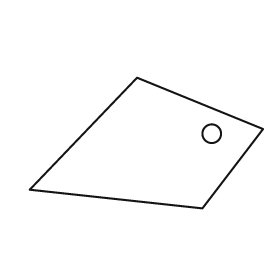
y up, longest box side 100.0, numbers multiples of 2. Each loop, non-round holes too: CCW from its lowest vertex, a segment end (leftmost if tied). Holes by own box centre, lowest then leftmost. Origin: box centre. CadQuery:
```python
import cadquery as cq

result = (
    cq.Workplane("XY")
    .moveTo(24.0, -28.0)
    .lineTo(50.0, 6.0)
    .lineTo(-4.0, 28.0)
    .lineTo(-50.0, -20.0)
    .close()
    .moveTo(28.0, 4.0)
    .circle(4.0)
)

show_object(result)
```